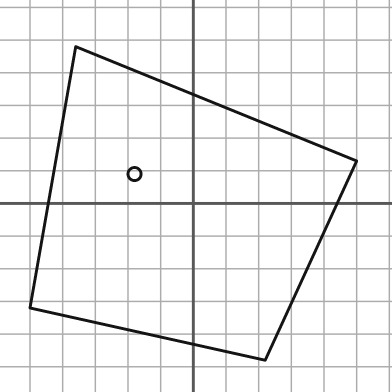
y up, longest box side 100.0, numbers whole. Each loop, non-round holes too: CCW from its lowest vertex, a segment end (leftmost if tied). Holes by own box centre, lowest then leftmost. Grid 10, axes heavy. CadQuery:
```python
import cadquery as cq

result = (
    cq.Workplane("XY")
    .moveTo(22.0, -48.0)
    .lineTo(50.0, 13.0)
    .lineTo(-36.0, 48.0)
    .lineTo(-50.0, -32.0)
    .close()
    .moveTo(-18.0, 9.0)
    .circle(2.0)
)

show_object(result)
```